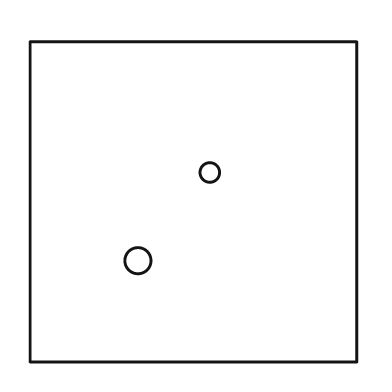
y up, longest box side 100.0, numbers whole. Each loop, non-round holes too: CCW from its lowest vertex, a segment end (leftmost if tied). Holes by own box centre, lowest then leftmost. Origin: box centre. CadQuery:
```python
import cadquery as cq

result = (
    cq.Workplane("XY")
    .moveTo(-50.0, -49.0)
    .lineTo(50.0, -49.0)
    .lineTo(50.0, 49.0)
    .lineTo(-50.0, 49.0)
    .close()
    .moveTo(-17.0, -18.0)
    .circle(4.0)
    .moveTo(5.0, 9.0)
    .circle(3.0)
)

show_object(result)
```